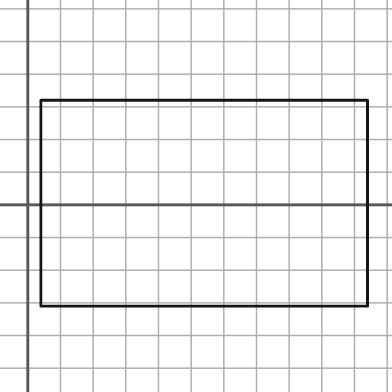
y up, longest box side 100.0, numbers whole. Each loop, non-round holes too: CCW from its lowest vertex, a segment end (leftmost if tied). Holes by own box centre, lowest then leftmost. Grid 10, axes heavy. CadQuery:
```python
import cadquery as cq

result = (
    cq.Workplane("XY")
    .moveTo(4.0, -31.0)
    .lineTo(104.0, -31.0)
    .lineTo(104.0, 32.0)
    .lineTo(4.0, 32.0)
    .close()
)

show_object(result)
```